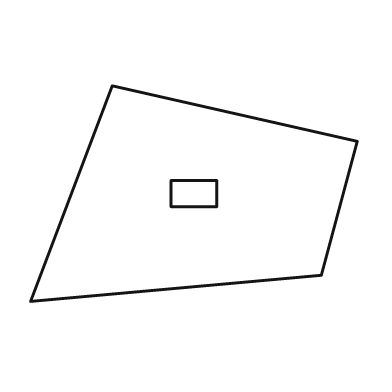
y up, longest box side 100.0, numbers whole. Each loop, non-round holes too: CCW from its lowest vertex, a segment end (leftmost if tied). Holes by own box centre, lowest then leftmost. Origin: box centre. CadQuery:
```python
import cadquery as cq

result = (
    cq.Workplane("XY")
    .moveTo(-50.0, -33.0)
    .lineTo(39.0, -25.0)
    .lineTo(50.0, 16.0)
    .lineTo(-25.0, 33.0)
    .close()
    .moveTo(-7.0, -4.0)
    .lineTo(7.0, -4.0)
    .lineTo(7.0, 4.0)
    .lineTo(-7.0, 4.0)
    .close()
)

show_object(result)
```